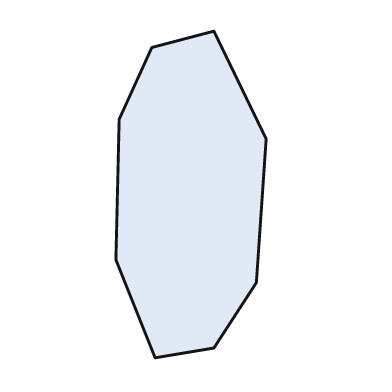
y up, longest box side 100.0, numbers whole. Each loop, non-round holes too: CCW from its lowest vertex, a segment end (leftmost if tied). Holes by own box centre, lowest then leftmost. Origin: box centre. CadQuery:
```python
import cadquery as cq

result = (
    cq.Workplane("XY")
    .moveTo(-11.0, -50.0)
    .lineTo(7.0, -47.0)
    .lineTo(20.0, -27.0)
    .lineTo(23.0, 17.0)
    .lineTo(7.0, 50.0)
    .lineTo(-12.0, 45.0)
    .lineTo(-22.0, 23.0)
    .lineTo(-23.0, -20.0)
    .close()
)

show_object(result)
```